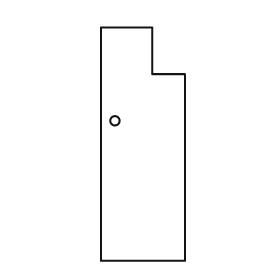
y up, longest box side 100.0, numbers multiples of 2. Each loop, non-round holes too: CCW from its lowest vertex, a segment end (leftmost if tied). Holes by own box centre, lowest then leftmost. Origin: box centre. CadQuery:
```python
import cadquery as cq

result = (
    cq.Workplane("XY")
    .moveTo(-18.0, -50.0)
    .lineTo(18.0, -50.0)
    .lineTo(18.0, 30.0)
    .lineTo(4.0, 30.0)
    .lineTo(4.0, 50.0)
    .lineTo(-18.0, 50.0)
    .close()
    .moveTo(-12.0, 10.0)
    .circle(2.0)
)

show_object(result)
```